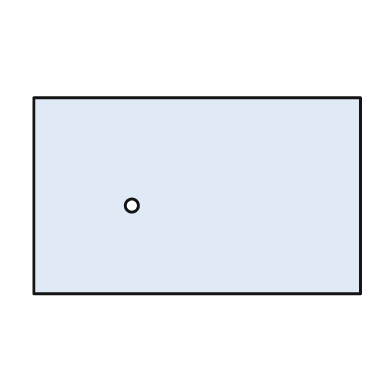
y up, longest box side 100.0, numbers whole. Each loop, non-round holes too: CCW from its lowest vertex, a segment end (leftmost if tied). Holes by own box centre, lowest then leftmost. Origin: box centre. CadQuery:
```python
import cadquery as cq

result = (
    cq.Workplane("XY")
    .moveTo(-50.0, -30.0)
    .lineTo(50.0, -30.0)
    .lineTo(50.0, 30.0)
    .lineTo(-50.0, 30.0)
    .close()
    .moveTo(-20.0, -3.0)
    .circle(2.0)
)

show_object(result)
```